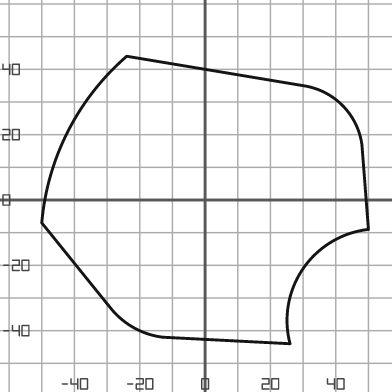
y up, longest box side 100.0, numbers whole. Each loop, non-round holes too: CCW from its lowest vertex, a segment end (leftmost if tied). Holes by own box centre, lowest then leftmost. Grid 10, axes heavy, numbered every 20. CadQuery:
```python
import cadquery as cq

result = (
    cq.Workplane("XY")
    .moveTo(26.0, -44.0)
    .threePointArc((30.0, -21.0), (50.0, -9.0))
    .lineTo(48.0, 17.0)
    .threePointArc((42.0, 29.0), (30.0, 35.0))
    .lineTo(-24.0, 44.0)
    .threePointArc((-42.0, 21.0), (-50.0, -7.0))
    .lineTo(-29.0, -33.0)
    .threePointArc((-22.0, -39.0), (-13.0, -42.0))
    .close()
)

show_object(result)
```